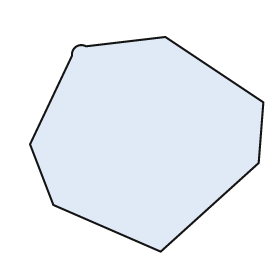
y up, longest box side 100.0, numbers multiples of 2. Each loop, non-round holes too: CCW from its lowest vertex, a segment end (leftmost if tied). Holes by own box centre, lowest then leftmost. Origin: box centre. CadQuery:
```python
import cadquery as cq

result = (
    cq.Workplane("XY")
    .moveTo(6.0, -46.0)
    .lineTo(48.0, -8.0)
    .lineTo(50.0, 18.0)
    .lineTo(8.0, 46.0)
    .lineTo(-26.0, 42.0)
    .threePointArc((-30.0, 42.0), (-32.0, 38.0))
    .lineTo(-50.0, 0.0)
    .lineTo(-40.0, -26.0)
    .close()
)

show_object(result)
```